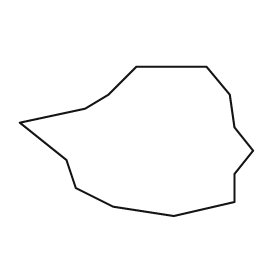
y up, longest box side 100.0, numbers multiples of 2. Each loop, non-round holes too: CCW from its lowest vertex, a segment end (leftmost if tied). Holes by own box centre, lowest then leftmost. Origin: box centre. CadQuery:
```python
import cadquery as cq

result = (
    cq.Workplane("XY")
    .moveTo(16.0, -32.0)
    .lineTo(42.0, -26.0)
    .lineTo(42.0, -14.0)
    .lineTo(50.0, -4.0)
    .lineTo(42.0, 6.0)
    .lineTo(40.0, 20.0)
    .lineTo(30.0, 32.0)
    .lineTo(0.0, 32.0)
    .lineTo(-12.0, 20.0)
    .lineTo(-22.0, 14.0)
    .lineTo(-50.0, 8.0)
    .lineTo(-30.0, -8.0)
    .lineTo(-26.0, -20.0)
    .lineTo(-10.0, -28.0)
    .close()
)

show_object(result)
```